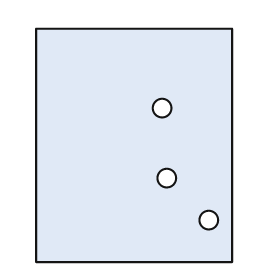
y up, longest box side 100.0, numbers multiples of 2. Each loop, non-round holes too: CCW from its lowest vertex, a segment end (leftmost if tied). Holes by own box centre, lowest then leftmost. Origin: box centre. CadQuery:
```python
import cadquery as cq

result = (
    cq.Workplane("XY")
    .moveTo(-42.0, -50.0)
    .lineTo(42.0, -50.0)
    .lineTo(42.0, 50.0)
    .lineTo(-42.0, 50.0)
    .close()
    .moveTo(32.0, -32.0)
    .circle(4.0)
    .moveTo(14.0, -14.0)
    .circle(4.0)
    .moveTo(12.0, 16.0)
    .circle(4.0)
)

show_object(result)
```